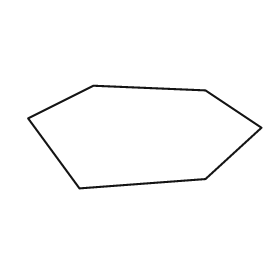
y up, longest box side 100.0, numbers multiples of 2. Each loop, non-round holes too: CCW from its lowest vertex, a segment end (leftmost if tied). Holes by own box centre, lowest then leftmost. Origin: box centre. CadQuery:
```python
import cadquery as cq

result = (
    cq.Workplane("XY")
    .moveTo(-28.0, -22.0)
    .lineTo(26.0, -18.0)
    .lineTo(50.0, 4.0)
    .lineTo(26.0, 20.0)
    .lineTo(-22.0, 22.0)
    .lineTo(-50.0, 8.0)
    .close()
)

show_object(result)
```